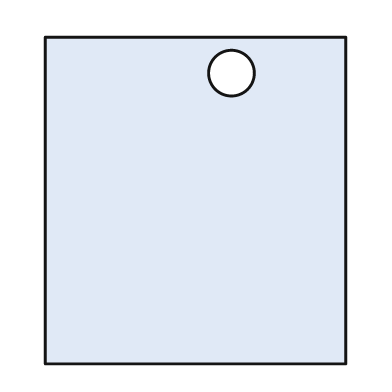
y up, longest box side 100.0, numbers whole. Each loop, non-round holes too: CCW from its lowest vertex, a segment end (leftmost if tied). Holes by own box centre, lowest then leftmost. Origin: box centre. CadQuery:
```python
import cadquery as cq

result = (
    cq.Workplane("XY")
    .moveTo(-46.0, -50.0)
    .lineTo(46.0, -50.0)
    .lineTo(46.0, 50.0)
    .lineTo(-46.0, 50.0)
    .close()
    .moveTo(11.0, 39.0)
    .circle(7.0)
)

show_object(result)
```